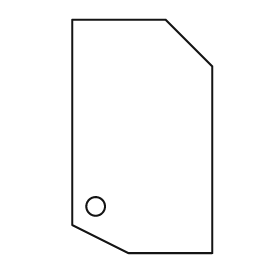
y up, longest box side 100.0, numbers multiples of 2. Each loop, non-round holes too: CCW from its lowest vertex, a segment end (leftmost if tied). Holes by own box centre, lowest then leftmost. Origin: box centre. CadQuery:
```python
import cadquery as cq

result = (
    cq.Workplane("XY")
    .moveTo(-6.0, -50.0)
    .lineTo(30.0, -50.0)
    .lineTo(30.0, 30.0)
    .lineTo(10.0, 50.0)
    .lineTo(-30.0, 50.0)
    .lineTo(-30.0, -38.0)
    .close()
    .moveTo(-20.0, -30.0)
    .circle(4.0)
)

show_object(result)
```